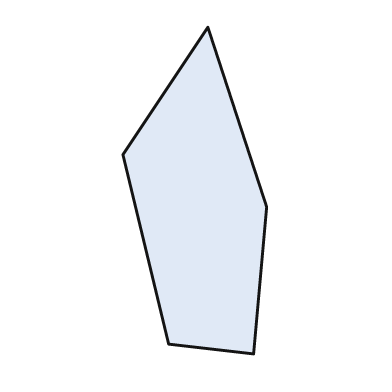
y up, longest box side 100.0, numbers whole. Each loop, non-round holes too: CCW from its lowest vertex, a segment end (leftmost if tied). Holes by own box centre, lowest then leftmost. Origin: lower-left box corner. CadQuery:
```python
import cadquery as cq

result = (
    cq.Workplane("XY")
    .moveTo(40.0, 0.0)
    .lineTo(44.0, 45.0)
    .lineTo(26.0, 100.0)
    .lineTo(0.0, 61.0)
    .lineTo(14.0, 3.0)
    .close()
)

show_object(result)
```